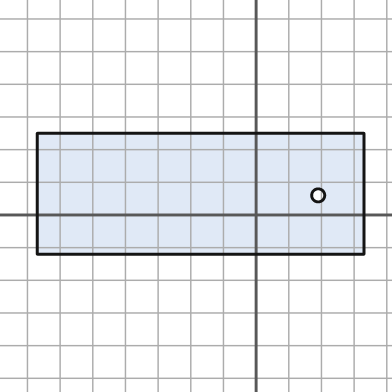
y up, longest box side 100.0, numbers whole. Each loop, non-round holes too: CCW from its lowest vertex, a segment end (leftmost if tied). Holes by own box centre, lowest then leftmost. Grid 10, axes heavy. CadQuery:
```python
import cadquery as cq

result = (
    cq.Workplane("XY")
    .moveTo(-67.0, -12.0)
    .lineTo(33.0, -12.0)
    .lineTo(33.0, 25.0)
    .lineTo(-67.0, 25.0)
    .close()
    .moveTo(19.0, 6.0)
    .circle(2.0)
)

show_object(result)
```